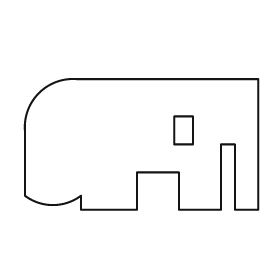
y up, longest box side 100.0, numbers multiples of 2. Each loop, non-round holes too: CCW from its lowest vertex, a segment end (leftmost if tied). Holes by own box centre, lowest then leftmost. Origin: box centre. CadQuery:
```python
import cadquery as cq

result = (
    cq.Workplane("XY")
    .moveTo(-26.0, -28.0)
    .lineTo(-2.0, -28.0)
    .lineTo(-2.0, -12.0)
    .lineTo(16.0, -12.0)
    .lineTo(16.0, -28.0)
    .lineTo(34.0, -28.0)
    .lineTo(34.0, 0.0)
    .lineTo(40.0, 0.0)
    .lineTo(40.0, -28.0)
    .lineTo(50.0, -28.0)
    .lineTo(50.0, 28.0)
    .lineTo(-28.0, 28.0)
    .threePointArc((-44.0, 22.0), (-50.0, 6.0))
    .lineTo(-50.0, -22.0)
    .threePointArc((-38.0, -26.0), (-26.0, -22.0))
    .close()
    .moveTo(14.0, 0.0)
    .lineTo(22.0, 0.0)
    .lineTo(22.0, 12.0)
    .lineTo(14.0, 12.0)
    .close()
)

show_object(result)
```